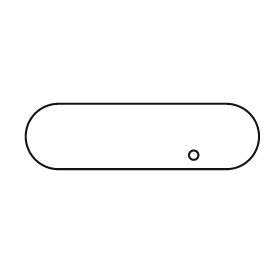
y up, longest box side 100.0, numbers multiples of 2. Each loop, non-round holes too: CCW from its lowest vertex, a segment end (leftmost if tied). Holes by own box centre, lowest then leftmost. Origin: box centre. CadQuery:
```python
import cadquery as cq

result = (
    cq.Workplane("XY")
    .moveTo(-36.0, -14.0)
    .lineTo(36.0, -14.0)
    .threePointArc((50.0, 0.0), (36.0, 14.0))
    .lineTo(-36.0, 14.0)
    .threePointArc((-50.0, 0.0), (-36.0, -14.0))
    .close()
    .moveTo(22.0, -8.0)
    .circle(2.0)
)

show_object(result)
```